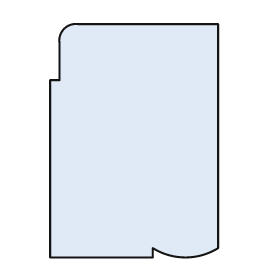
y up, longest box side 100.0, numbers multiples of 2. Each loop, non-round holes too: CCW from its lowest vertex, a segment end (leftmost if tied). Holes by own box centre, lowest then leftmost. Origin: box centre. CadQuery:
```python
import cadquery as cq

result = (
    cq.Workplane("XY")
    .moveTo(-36.0, -50.0)
    .lineTo(8.0, -50.0)
    .lineTo(8.0, -46.0)
    .threePointArc((22.0, -50.0), (36.0, -46.0))
    .lineTo(36.0, 50.0)
    .lineTo(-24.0, 50.0)
    .threePointArc((-30.0, 48.0), (-32.0, 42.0))
    .lineTo(-32.0, 26.0)
    .lineTo(-36.0, 26.0)
    .close()
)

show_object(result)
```